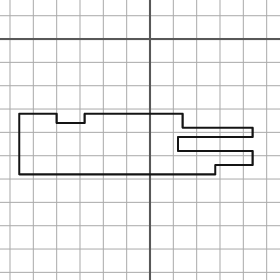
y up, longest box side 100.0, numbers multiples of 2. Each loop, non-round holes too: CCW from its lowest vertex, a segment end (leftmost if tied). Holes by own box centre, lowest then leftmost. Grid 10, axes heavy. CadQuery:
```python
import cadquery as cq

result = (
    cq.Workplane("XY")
    .moveTo(-56.0, -58.0)
    .lineTo(28.0, -58.0)
    .lineTo(28.0, -54.0)
    .lineTo(44.0, -54.0)
    .lineTo(44.0, -48.0)
    .lineTo(12.0, -48.0)
    .lineTo(12.0, -42.0)
    .lineTo(44.0, -42.0)
    .lineTo(44.0, -38.0)
    .lineTo(14.0, -38.0)
    .lineTo(14.0, -32.0)
    .lineTo(-28.0, -32.0)
    .lineTo(-28.0, -36.0)
    .lineTo(-40.0, -36.0)
    .lineTo(-40.0, -32.0)
    .lineTo(-56.0, -32.0)
    .close()
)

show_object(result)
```